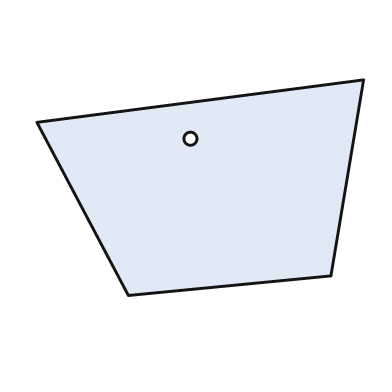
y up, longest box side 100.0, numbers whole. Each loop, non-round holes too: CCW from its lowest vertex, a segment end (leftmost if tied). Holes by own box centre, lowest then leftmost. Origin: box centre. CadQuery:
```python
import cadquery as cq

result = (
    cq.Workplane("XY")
    .moveTo(-22.0, -33.0)
    .lineTo(40.0, -27.0)
    .lineTo(50.0, 33.0)
    .lineTo(-50.0, 20.0)
    .close()
    .moveTo(-3.0, 15.0)
    .circle(2.0)
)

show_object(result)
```